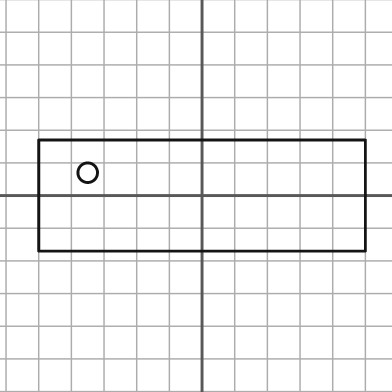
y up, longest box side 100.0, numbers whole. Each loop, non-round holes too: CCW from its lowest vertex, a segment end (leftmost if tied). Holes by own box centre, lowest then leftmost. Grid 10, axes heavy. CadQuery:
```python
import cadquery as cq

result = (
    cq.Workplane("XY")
    .moveTo(-50.0, -17.0)
    .lineTo(50.0, -17.0)
    .lineTo(50.0, 17.0)
    .lineTo(-50.0, 17.0)
    .close()
    .moveTo(-35.0, 7.0)
    .circle(3.0)
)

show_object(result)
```